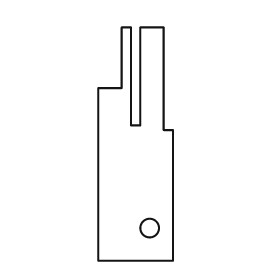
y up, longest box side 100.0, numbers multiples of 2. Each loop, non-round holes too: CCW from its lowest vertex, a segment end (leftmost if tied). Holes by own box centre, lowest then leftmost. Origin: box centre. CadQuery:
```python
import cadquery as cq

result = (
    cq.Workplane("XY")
    .moveTo(-16.0, -50.0)
    .lineTo(16.0, -50.0)
    .lineTo(16.0, 6.0)
    .lineTo(12.0, 6.0)
    .lineTo(12.0, 50.0)
    .lineTo(2.0, 50.0)
    .lineTo(2.0, 8.0)
    .lineTo(-2.0, 8.0)
    .lineTo(-2.0, 50.0)
    .lineTo(-6.0, 50.0)
    .lineTo(-6.0, 24.0)
    .lineTo(-16.0, 24.0)
    .close()
    .moveTo(6.0, -36.0)
    .circle(4.0)
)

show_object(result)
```